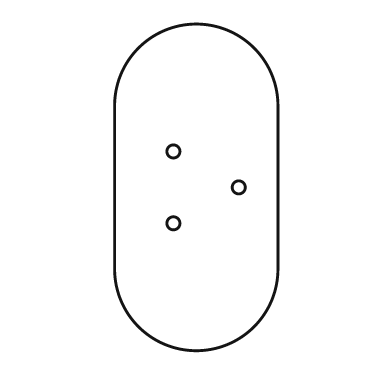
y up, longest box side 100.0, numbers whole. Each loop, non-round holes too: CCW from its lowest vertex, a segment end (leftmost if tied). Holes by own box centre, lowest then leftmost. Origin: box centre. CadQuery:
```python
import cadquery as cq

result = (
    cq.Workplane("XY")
    .moveTo(-25.0, -25.0)
    .threePointArc((0.0, -50.0), (25.0, -25.0))
    .lineTo(25.0, 25.0)
    .threePointArc((0.0, 50.0), (-25.0, 25.0))
    .close()
    .moveTo(-7.0, -11.0)
    .circle(2.0)
    .moveTo(13.0, 0.0)
    .circle(2.0)
    .moveTo(-7.0, 11.0)
    .circle(2.0)
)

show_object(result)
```